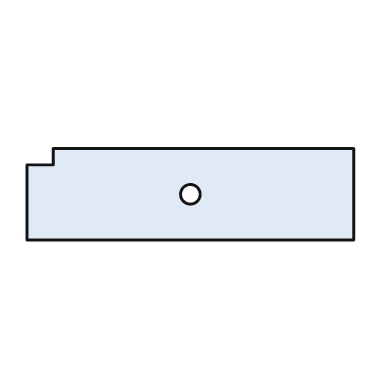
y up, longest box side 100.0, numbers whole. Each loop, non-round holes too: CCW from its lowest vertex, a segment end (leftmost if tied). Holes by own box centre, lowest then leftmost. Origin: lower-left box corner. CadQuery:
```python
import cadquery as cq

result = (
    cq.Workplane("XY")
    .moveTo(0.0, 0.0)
    .lineTo(100.0, 0.0)
    .lineTo(100.0, 28.0)
    .lineTo(8.0, 28.0)
    .lineTo(8.0, 23.0)
    .lineTo(0.0, 23.0)
    .close()
    .moveTo(50.0, 14.0)
    .circle(3.0)
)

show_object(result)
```